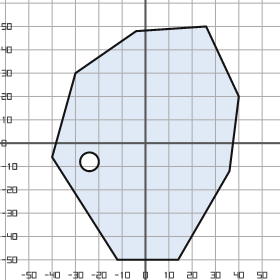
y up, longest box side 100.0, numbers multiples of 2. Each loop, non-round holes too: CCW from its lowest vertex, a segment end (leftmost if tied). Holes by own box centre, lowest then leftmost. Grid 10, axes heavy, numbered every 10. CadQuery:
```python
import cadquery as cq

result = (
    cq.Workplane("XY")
    .moveTo(-12.0, -50.0)
    .lineTo(14.0, -50.0)
    .lineTo(36.0, -12.0)
    .lineTo(40.0, 20.0)
    .lineTo(26.0, 50.0)
    .lineTo(-4.0, 48.0)
    .lineTo(-30.0, 30.0)
    .lineTo(-40.0, -6.0)
    .close()
    .moveTo(-24.0, -8.0)
    .circle(4.0)
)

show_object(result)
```